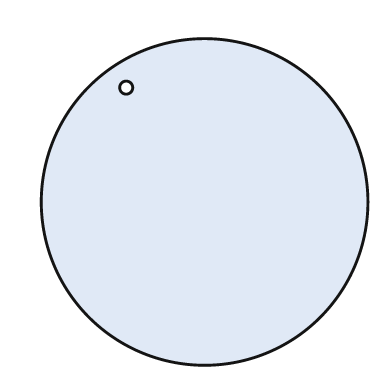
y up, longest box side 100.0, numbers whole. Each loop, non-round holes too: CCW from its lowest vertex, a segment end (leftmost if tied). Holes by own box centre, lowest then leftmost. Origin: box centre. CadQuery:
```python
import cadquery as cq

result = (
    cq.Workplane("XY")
    .moveTo(0.0, 0.0)
    .circle(50.0)
    .moveTo(-24.0, 35.0)
    .circle(2.0)
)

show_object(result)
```